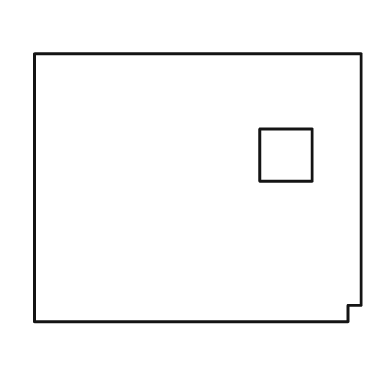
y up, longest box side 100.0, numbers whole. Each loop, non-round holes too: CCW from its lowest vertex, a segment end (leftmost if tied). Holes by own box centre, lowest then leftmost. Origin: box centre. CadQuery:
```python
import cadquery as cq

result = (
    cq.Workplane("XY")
    .moveTo(-50.0, -41.0)
    .lineTo(46.0, -41.0)
    .lineTo(46.0, -36.0)
    .lineTo(50.0, -36.0)
    .lineTo(50.0, 41.0)
    .lineTo(-50.0, 41.0)
    .close()
    .moveTo(19.0, 2.0)
    .lineTo(35.0, 2.0)
    .lineTo(35.0, 18.0)
    .lineTo(19.0, 18.0)
    .close()
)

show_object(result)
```